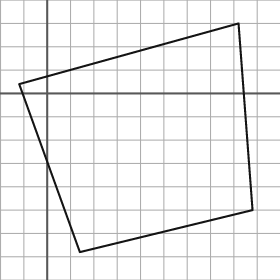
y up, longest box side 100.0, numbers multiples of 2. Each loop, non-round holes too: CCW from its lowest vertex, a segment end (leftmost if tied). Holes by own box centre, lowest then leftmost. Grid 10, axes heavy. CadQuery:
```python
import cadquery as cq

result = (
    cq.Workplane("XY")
    .moveTo(14.0, -68.0)
    .lineTo(88.0, -50.0)
    .lineTo(82.0, 30.0)
    .lineTo(-12.0, 4.0)
    .close()
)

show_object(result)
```